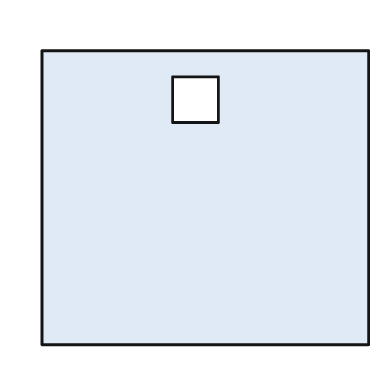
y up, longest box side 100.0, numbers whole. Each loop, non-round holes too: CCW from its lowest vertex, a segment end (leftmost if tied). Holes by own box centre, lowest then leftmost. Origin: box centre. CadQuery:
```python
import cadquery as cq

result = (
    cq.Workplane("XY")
    .moveTo(-50.0, -45.0)
    .lineTo(50.0, -45.0)
    .lineTo(50.0, 45.0)
    .lineTo(-50.0, 45.0)
    .close()
    .moveTo(-10.0, 23.0)
    .lineTo(4.0, 23.0)
    .lineTo(4.0, 37.0)
    .lineTo(-10.0, 37.0)
    .close()
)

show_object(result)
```